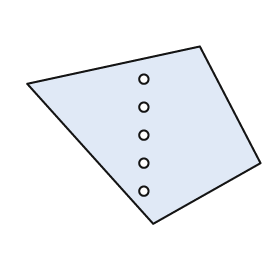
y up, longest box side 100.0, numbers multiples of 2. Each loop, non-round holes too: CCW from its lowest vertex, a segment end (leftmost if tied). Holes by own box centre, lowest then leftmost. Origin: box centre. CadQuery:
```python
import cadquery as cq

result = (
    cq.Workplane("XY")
    .moveTo(4.0, -38.0)
    .lineTo(50.0, -12.0)
    .lineTo(24.0, 38.0)
    .lineTo(-50.0, 22.0)
    .close()
    .moveTo(0.0, -24.0)
    .circle(2.0)
    .moveTo(0.0, -12.0)
    .circle(2.0)
    .moveTo(0.0, 0.0)
    .circle(2.0)
    .moveTo(0.0, 12.0)
    .circle(2.0)
    .moveTo(0.0, 24.0)
    .circle(2.0)
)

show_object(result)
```